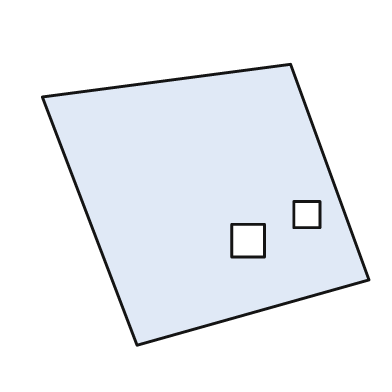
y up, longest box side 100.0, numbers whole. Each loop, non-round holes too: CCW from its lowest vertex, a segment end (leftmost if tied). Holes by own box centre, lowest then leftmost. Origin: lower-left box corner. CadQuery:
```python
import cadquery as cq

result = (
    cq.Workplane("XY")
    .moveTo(29.0, 0.0)
    .lineTo(100.0, 20.0)
    .lineTo(76.0, 86.0)
    .lineTo(0.0, 76.0)
    .close()
    .moveTo(58.0, 27.0)
    .lineTo(68.0, 27.0)
    .lineTo(68.0, 37.0)
    .lineTo(58.0, 37.0)
    .close()
    .moveTo(77.0, 36.0)
    .lineTo(85.0, 36.0)
    .lineTo(85.0, 44.0)
    .lineTo(77.0, 44.0)
    .close()
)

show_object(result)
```